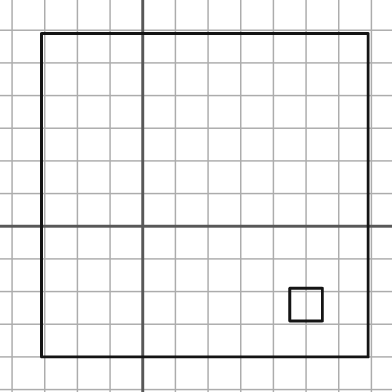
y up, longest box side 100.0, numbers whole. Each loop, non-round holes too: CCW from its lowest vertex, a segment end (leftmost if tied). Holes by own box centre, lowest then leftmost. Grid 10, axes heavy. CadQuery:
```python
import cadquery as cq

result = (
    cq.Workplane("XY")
    .moveTo(-31.0, -40.0)
    .lineTo(69.0, -40.0)
    .lineTo(69.0, 59.0)
    .lineTo(-31.0, 59.0)
    .close()
    .moveTo(45.0, -29.0)
    .lineTo(55.0, -29.0)
    .lineTo(55.0, -19.0)
    .lineTo(45.0, -19.0)
    .close()
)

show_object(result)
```